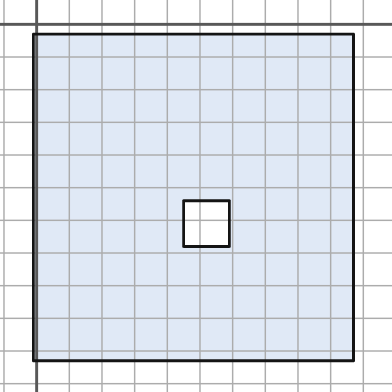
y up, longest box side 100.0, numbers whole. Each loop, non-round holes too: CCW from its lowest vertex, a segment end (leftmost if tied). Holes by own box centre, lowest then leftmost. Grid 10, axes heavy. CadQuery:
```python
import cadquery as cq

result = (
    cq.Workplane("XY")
    .moveTo(-1.0, -103.0)
    .lineTo(97.0, -103.0)
    .lineTo(97.0, -3.0)
    .lineTo(-1.0, -3.0)
    .close()
    .moveTo(45.0, -68.0)
    .lineTo(59.0, -68.0)
    .lineTo(59.0, -54.0)
    .lineTo(45.0, -54.0)
    .close()
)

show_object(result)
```